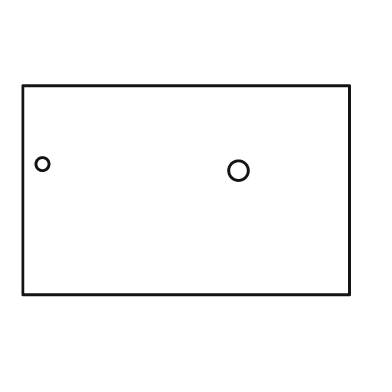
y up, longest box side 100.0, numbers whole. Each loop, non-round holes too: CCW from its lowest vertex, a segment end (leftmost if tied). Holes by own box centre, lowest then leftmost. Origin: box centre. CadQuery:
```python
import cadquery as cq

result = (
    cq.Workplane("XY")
    .moveTo(-50.0, -32.0)
    .lineTo(50.0, -32.0)
    .lineTo(50.0, 32.0)
    .lineTo(-50.0, 32.0)
    .close()
    .moveTo(16.0, 6.0)
    .circle(3.0)
    .moveTo(-44.0, 8.0)
    .circle(2.0)
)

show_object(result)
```